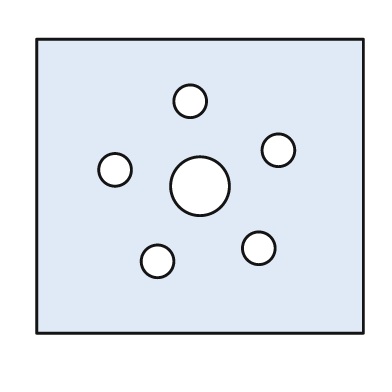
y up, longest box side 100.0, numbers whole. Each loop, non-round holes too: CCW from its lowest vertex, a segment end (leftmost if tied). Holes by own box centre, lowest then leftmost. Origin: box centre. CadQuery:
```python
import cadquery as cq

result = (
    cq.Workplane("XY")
    .moveTo(-50.0, -45.0)
    .lineTo(50.0, -45.0)
    .lineTo(50.0, 45.0)
    .lineTo(-50.0, 45.0)
    .close()
    .moveTo(-13.0, -23.0)
    .circle(5.0)
    .moveTo(18.0, -19.0)
    .circle(5.0)
    .moveTo(0.0, 0.0)
    .circle(9.0)
    .moveTo(-26.0, 5.0)
    .circle(5.0)
    .moveTo(24.0, 11.0)
    .circle(5.0)
    .moveTo(-3.0, 26.0)
    .circle(5.0)
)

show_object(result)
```